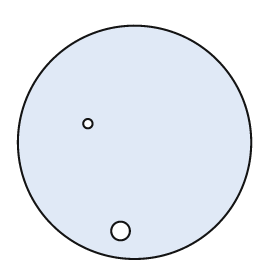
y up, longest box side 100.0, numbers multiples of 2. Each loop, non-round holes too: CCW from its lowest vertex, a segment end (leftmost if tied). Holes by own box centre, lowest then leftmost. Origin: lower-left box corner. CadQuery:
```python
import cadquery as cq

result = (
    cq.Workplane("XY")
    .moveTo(50.0, 50.0)
    .circle(50.0)
    .moveTo(44.0, 12.0)
    .circle(4.0)
    .moveTo(30.0, 58.0)
    .circle(2.0)
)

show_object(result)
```